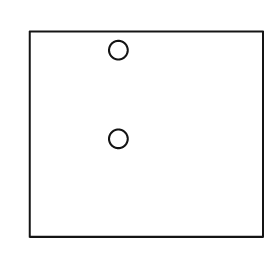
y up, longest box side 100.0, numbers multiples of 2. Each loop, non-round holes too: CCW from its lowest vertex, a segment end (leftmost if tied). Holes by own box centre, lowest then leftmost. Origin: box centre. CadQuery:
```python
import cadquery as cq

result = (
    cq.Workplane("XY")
    .moveTo(-50.0, -44.0)
    .lineTo(50.0, -44.0)
    .lineTo(50.0, 44.0)
    .lineTo(-50.0, 44.0)
    .close()
    .moveTo(-12.0, -2.0)
    .circle(4.0)
    .moveTo(-12.0, 36.0)
    .circle(4.0)
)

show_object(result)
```